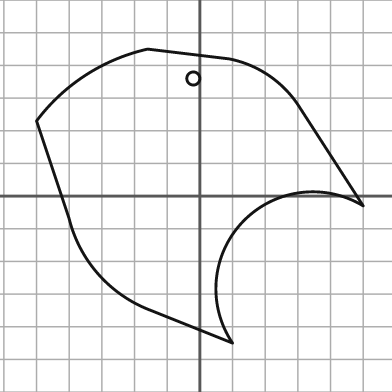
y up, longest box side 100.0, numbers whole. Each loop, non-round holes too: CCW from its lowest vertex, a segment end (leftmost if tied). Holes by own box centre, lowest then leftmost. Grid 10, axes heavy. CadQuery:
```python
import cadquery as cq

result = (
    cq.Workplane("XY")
    .moveTo(10.0, -45.0)
    .threePointArc((13.0, -8.0), (50.0, -3.0))
    .lineTo(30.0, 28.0)
    .threePointArc((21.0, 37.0), (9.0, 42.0))
    .lineTo(-16.0, 45.0)
    .threePointArc((-35.0, 37.0), (-50.0, 23.0))
    .lineTo(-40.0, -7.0)
    .threePointArc((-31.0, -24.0), (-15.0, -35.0))
    .close()
    .moveTo(-2.0, 36.0)
    .circle(2.0)
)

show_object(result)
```